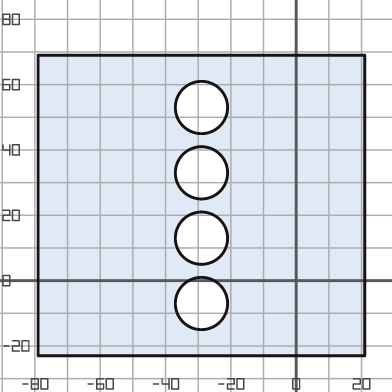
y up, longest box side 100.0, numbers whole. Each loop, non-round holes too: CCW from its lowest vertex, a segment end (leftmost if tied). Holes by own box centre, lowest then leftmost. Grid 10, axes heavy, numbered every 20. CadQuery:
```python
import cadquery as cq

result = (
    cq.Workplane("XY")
    .moveTo(-79.0, -23.0)
    .lineTo(21.0, -23.0)
    .lineTo(21.0, 69.0)
    .lineTo(-79.0, 69.0)
    .close()
    .moveTo(-29.0, -7.0)
    .circle(8.0)
    .moveTo(-29.0, 13.0)
    .circle(8.0)
    .moveTo(-29.0, 33.0)
    .circle(8.0)
    .moveTo(-29.0, 53.0)
    .circle(8.0)
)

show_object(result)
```